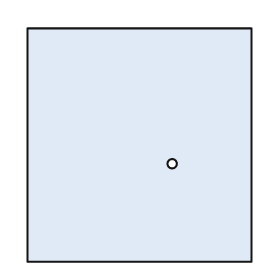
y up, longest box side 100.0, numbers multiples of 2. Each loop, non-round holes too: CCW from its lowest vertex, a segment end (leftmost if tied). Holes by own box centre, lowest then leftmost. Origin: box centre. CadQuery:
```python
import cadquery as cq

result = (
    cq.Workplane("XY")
    .moveTo(-48.0, -50.0)
    .lineTo(48.0, -50.0)
    .lineTo(48.0, 50.0)
    .lineTo(-48.0, 50.0)
    .close()
    .moveTo(14.0, -8.0)
    .circle(2.0)
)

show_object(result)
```